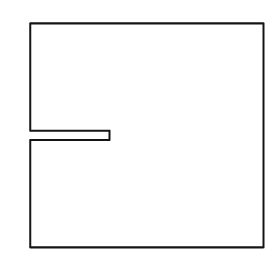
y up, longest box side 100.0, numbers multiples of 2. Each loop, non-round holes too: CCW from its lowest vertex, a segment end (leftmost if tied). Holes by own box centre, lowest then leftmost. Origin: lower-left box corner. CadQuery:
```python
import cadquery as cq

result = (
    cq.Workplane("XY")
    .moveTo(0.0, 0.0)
    .lineTo(100.0, 0.0)
    .lineTo(100.0, 96.0)
    .lineTo(0.0, 96.0)
    .lineTo(0.0, 50.0)
    .lineTo(34.0, 50.0)
    .lineTo(34.0, 46.0)
    .lineTo(0.0, 46.0)
    .close()
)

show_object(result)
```